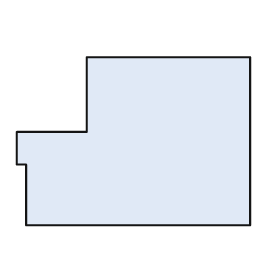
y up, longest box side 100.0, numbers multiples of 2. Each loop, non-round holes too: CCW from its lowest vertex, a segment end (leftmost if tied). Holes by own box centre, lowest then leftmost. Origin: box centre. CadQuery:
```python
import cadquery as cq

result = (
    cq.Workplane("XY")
    .moveTo(-46.0, -36.0)
    .lineTo(50.0, -36.0)
    .lineTo(50.0, 36.0)
    .lineTo(-20.0, 36.0)
    .lineTo(-20.0, 4.0)
    .lineTo(-50.0, 4.0)
    .lineTo(-50.0, -10.0)
    .lineTo(-46.0, -10.0)
    .close()
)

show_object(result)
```